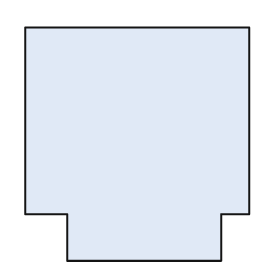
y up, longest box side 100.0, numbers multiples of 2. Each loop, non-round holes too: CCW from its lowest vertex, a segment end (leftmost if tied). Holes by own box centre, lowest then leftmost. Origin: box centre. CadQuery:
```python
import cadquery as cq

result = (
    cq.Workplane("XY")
    .moveTo(-30.0, -50.0)
    .lineTo(36.0, -50.0)
    .lineTo(36.0, -30.0)
    .lineTo(48.0, -30.0)
    .lineTo(48.0, 50.0)
    .lineTo(-48.0, 50.0)
    .lineTo(-48.0, -30.0)
    .lineTo(-30.0, -30.0)
    .close()
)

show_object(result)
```